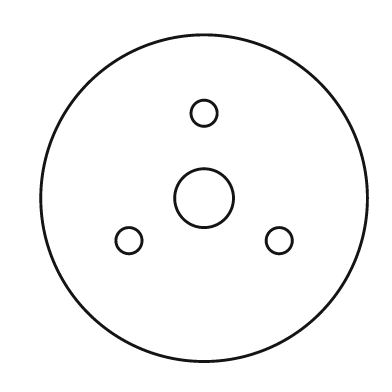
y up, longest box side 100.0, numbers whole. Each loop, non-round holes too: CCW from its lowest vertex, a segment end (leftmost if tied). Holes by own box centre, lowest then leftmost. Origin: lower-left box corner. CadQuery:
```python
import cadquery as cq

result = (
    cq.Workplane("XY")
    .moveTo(50.0, 50.0)
    .circle(50.0)
    .moveTo(27.0, 37.0)
    .circle(4.0)
    .moveTo(73.0, 37.0)
    .circle(4.0)
    .moveTo(50.0, 50.0)
    .circle(9.0)
    .moveTo(50.0, 76.0)
    .circle(4.0)
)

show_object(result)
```